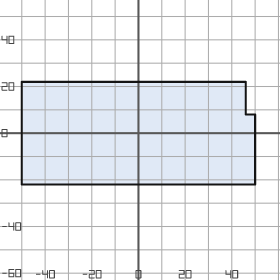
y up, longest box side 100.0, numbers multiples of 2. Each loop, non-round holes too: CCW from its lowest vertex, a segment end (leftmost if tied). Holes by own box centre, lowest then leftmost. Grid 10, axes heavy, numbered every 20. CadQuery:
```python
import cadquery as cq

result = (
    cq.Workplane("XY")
    .moveTo(-50.0, -22.0)
    .lineTo(50.0, -22.0)
    .lineTo(50.0, 8.0)
    .lineTo(46.0, 8.0)
    .lineTo(46.0, 22.0)
    .lineTo(-50.0, 22.0)
    .close()
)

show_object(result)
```